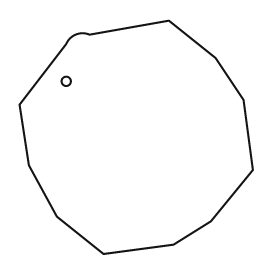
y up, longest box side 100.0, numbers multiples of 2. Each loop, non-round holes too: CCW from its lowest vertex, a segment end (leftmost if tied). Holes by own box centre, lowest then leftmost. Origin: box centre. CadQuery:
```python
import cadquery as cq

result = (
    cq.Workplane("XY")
    .moveTo(-14.0, -50.0)
    .lineTo(16.0, -46.0)
    .lineTo(32.0, -36.0)
    .lineTo(50.0, -14.0)
    .lineTo(46.0, 16.0)
    .lineTo(34.0, 34.0)
    .lineTo(14.0, 50.0)
    .lineTo(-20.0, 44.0)
    .threePointArc((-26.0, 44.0), (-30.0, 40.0))
    .lineTo(-50.0, 14.0)
    .lineTo(-46.0, -12.0)
    .lineTo(-34.0, -34.0)
    .close()
    .moveTo(-30.0, 24.0)
    .circle(2.0)
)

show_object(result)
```